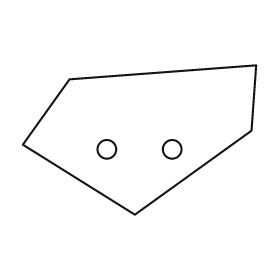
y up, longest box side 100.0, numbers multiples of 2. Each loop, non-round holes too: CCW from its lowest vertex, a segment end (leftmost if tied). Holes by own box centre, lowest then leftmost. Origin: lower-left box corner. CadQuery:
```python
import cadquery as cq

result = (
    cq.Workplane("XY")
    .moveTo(48.0, 0.0)
    .lineTo(98.0, 36.0)
    .lineTo(100.0, 64.0)
    .lineTo(20.0, 58.0)
    .lineTo(0.0, 30.0)
    .close()
    .moveTo(36.0, 28.0)
    .circle(4.0)
    .moveTo(64.0, 28.0)
    .circle(4.0)
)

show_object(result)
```